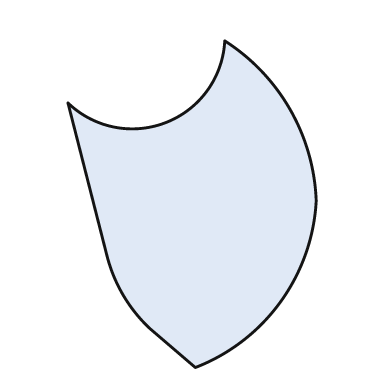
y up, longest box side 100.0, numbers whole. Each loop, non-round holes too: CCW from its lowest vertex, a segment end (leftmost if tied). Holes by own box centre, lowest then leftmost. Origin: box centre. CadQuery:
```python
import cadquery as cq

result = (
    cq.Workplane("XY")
    .moveTo(1.0, -50.0)
    .threePointArc((27.0, -30.0), (38.0, 1.0))
    .threePointArc((30.0, 29.0), (10.0, 50.0))
    .threePointArc((-8.0, 25.0), (-38.0, 31.0))
    .lineTo(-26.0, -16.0)
    .threePointArc((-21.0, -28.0), (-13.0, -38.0))
    .close()
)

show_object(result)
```